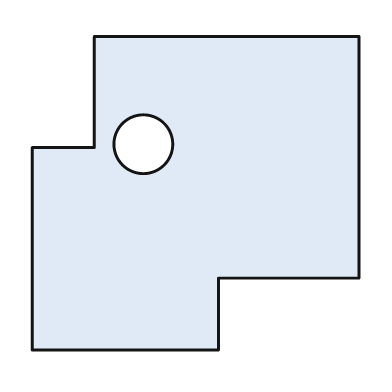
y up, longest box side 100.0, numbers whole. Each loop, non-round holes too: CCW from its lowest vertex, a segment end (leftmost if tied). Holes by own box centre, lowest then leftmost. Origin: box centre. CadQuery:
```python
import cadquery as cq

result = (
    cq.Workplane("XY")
    .moveTo(-50.0, -48.0)
    .lineTo(7.0, -48.0)
    .lineTo(7.0, -26.0)
    .lineTo(50.0, -26.0)
    .lineTo(50.0, 48.0)
    .lineTo(-31.0, 48.0)
    .lineTo(-31.0, 14.0)
    .lineTo(-50.0, 14.0)
    .close()
    .moveTo(-16.0, 15.0)
    .circle(9.0)
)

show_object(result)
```